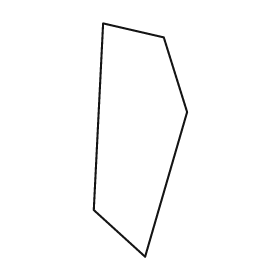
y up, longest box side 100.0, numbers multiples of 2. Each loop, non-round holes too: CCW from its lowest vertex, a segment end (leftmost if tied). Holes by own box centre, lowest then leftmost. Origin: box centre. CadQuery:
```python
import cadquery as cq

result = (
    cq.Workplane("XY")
    .moveTo(2.0, -50.0)
    .lineTo(20.0, 12.0)
    .lineTo(10.0, 44.0)
    .lineTo(-16.0, 50.0)
    .lineTo(-20.0, -30.0)
    .close()
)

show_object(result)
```